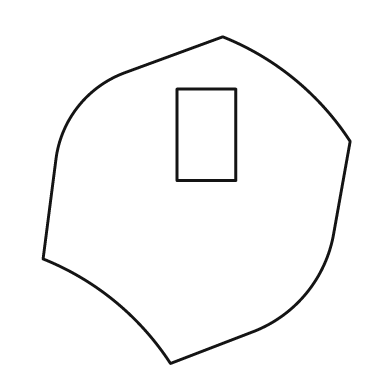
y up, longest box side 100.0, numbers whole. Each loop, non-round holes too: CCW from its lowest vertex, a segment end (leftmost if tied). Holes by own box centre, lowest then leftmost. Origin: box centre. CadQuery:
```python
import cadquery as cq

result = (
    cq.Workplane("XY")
    .moveTo(-8.0, -50.0)
    .lineTo(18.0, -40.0)
    .threePointArc((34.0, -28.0), (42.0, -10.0))
    .lineTo(47.0, 18.0)
    .threePointArc((30.0, 37.0), (8.0, 50.0))
    .lineTo(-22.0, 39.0)
    .threePointArc((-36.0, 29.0), (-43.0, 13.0))
    .lineTo(-47.0, -18.0)
    .threePointArc((-25.0, -31.0), (-8.0, -50.0))
    .close()
    .moveTo(-6.0, 6.0)
    .lineTo(12.0, 6.0)
    .lineTo(12.0, 34.0)
    .lineTo(-6.0, 34.0)
    .close()
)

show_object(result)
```